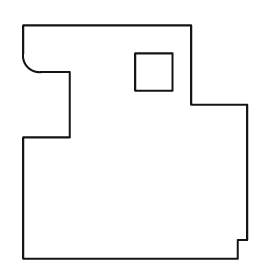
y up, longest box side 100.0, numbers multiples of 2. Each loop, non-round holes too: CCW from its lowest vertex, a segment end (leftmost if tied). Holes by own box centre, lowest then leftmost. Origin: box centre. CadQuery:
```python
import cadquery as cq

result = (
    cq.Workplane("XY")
    .moveTo(-48.0, -50.0)
    .lineTo(44.0, -50.0)
    .lineTo(44.0, -42.0)
    .lineTo(48.0, -42.0)
    .lineTo(48.0, 16.0)
    .lineTo(24.0, 16.0)
    .lineTo(24.0, 50.0)
    .lineTo(-48.0, 50.0)
    .lineTo(-48.0, 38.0)
    .threePointArc((-46.0, 32.0), (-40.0, 30.0))
    .lineTo(-28.0, 30.0)
    .lineTo(-28.0, 2.0)
    .lineTo(-48.0, 2.0)
    .close()
    .moveTo(0.0, 22.0)
    .lineTo(16.0, 22.0)
    .lineTo(16.0, 38.0)
    .lineTo(0.0, 38.0)
    .close()
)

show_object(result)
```